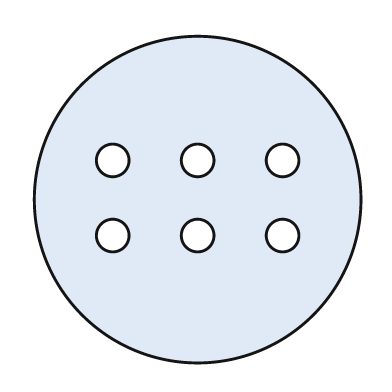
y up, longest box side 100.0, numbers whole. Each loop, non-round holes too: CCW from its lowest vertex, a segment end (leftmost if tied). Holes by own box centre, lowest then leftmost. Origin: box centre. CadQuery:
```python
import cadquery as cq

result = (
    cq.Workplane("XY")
    .moveTo(0.0, 0.0)
    .circle(50.0)
    .moveTo(-26.0, -11.0)
    .circle(5.0)
    .moveTo(0.0, -11.0)
    .circle(5.0)
    .moveTo(26.0, -11.0)
    .circle(5.0)
    .moveTo(-26.0, 12.0)
    .circle(5.0)
    .moveTo(0.0, 12.0)
    .circle(5.0)
    .moveTo(26.0, 12.0)
    .circle(5.0)
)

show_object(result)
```